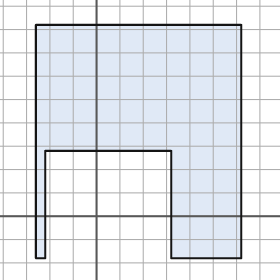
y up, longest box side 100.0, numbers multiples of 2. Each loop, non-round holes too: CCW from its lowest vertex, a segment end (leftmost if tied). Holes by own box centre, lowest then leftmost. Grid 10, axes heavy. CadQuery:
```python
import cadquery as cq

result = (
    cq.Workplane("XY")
    .moveTo(-26.0, -18.0)
    .lineTo(-22.0, -18.0)
    .lineTo(-22.0, 28.0)
    .lineTo(32.0, 28.0)
    .lineTo(32.0, -18.0)
    .lineTo(62.0, -18.0)
    .lineTo(62.0, 82.0)
    .lineTo(-26.0, 82.0)
    .close()
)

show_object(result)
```